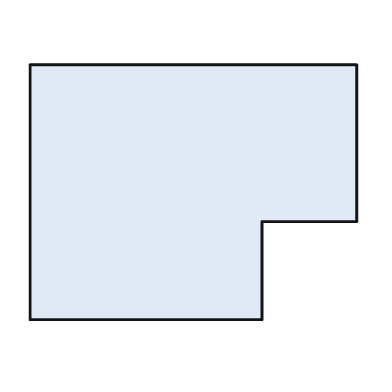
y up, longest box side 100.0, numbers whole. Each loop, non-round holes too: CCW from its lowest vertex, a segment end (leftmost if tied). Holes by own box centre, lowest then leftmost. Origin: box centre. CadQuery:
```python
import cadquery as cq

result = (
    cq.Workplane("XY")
    .moveTo(-50.0, -39.0)
    .lineTo(21.0, -39.0)
    .lineTo(21.0, -9.0)
    .lineTo(50.0, -9.0)
    .lineTo(50.0, 39.0)
    .lineTo(-50.0, 39.0)
    .close()
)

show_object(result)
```